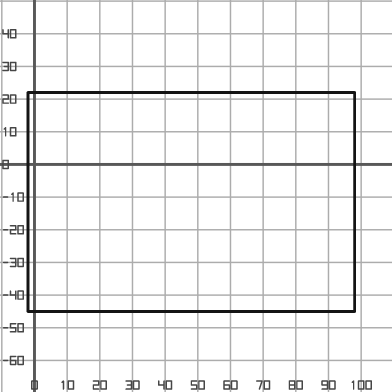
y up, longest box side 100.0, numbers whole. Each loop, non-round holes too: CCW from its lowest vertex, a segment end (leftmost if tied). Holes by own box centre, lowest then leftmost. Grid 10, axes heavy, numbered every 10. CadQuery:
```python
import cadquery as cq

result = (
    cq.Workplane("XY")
    .moveTo(-2.0, -45.0)
    .lineTo(98.0, -45.0)
    .lineTo(98.0, 22.0)
    .lineTo(-2.0, 22.0)
    .close()
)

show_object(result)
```